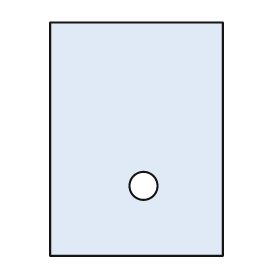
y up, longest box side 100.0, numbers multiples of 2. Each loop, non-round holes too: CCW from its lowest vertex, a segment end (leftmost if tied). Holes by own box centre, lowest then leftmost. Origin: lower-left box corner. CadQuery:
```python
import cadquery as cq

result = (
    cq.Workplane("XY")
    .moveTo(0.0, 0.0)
    .lineTo(74.0, 0.0)
    .lineTo(74.0, 100.0)
    .lineTo(0.0, 100.0)
    .close()
    .moveTo(40.0, 30.0)
    .circle(6.0)
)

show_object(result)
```